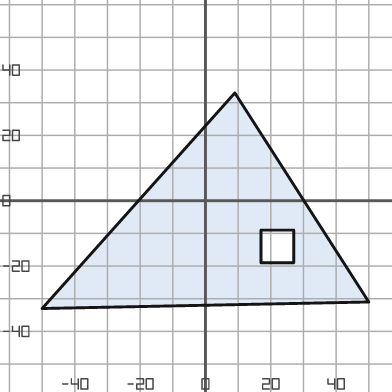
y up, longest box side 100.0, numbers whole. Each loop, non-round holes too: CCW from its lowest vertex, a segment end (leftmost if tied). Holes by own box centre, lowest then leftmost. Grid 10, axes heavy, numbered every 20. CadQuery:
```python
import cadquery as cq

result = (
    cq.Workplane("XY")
    .moveTo(-50.0, -33.0)
    .lineTo(50.0, -31.0)
    .lineTo(9.0, 33.0)
    .close()
    .moveTo(17.0, -19.0)
    .lineTo(27.0, -19.0)
    .lineTo(27.0, -9.0)
    .lineTo(17.0, -9.0)
    .close()
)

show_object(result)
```